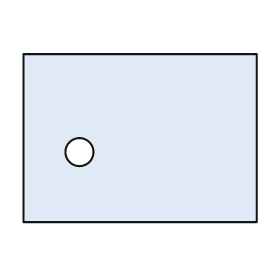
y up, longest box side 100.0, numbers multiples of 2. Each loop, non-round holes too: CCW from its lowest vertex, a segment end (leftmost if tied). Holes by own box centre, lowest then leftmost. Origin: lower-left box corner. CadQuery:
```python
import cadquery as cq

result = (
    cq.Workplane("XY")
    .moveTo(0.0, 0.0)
    .lineTo(100.0, 0.0)
    .lineTo(100.0, 72.0)
    .lineTo(0.0, 72.0)
    .close()
    .moveTo(24.0, 30.0)
    .circle(6.0)
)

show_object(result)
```